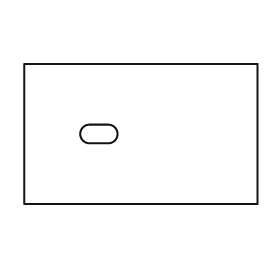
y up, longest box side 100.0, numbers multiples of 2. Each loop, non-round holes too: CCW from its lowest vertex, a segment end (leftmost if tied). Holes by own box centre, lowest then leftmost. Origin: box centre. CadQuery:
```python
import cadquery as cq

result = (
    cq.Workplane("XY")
    .moveTo(-50.0, -30.0)
    .lineTo(50.0, -30.0)
    .lineTo(50.0, 30.0)
    .lineTo(-50.0, 30.0)
    .close()
    .moveTo(-22.0, -4.0)
    .lineTo(-14.0, -4.0)
    .threePointArc((-10.0, 0.0), (-14.0, 4.0))
    .lineTo(-22.0, 4.0)
    .threePointArc((-26.0, 0.0), (-22.0, -4.0))
    .close()
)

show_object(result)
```